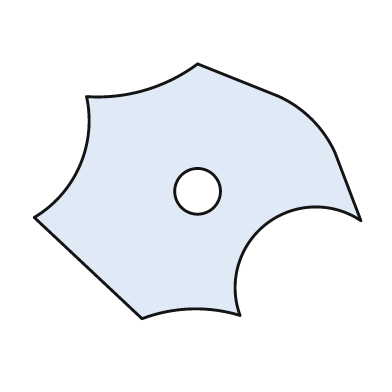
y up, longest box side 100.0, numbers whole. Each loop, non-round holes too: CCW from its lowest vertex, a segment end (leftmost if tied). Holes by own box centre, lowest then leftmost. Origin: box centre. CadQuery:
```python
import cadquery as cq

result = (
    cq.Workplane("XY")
    .moveTo(-17.0, -39.0)
    .threePointArc((-2.0, -36.0), (13.0, -38.0))
    .threePointArc((21.0, -10.0), (50.0, -9.0))
    .lineTo(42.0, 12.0)
    .threePointArc((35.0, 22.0), (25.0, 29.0))
    .lineTo(0.0, 39.0)
    .threePointArc((-16.0, 31.0), (-34.0, 29.0))
    .threePointArc((-36.0, 8.0), (-50.0, -8.0))
    .close()
    .moveTo(0.0, 0.0)
    .circle(7.0)
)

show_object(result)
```